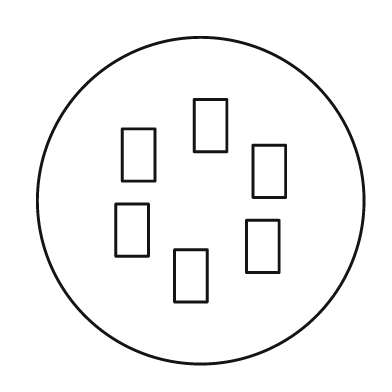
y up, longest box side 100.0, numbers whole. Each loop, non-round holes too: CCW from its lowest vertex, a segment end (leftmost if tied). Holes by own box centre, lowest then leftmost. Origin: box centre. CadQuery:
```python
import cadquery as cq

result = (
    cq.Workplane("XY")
    .moveTo(0.0, 0.0)
    .circle(50.0)
    .moveTo(-8.0, -31.0)
    .lineTo(2.0, -31.0)
    .lineTo(2.0, -15.0)
    .lineTo(-8.0, -15.0)
    .close()
    .moveTo(14.0, -22.0)
    .lineTo(24.0, -22.0)
    .lineTo(24.0, -6.0)
    .lineTo(14.0, -6.0)
    .close()
    .moveTo(-26.0, -17.0)
    .lineTo(-16.0, -17.0)
    .lineTo(-16.0, -1.0)
    .lineTo(-26.0, -1.0)
    .close()
    .moveTo(16.0, 1.0)
    .lineTo(26.0, 1.0)
    .lineTo(26.0, 17.0)
    .lineTo(16.0, 17.0)
    .close()
    .moveTo(-24.0, 6.0)
    .lineTo(-14.0, 6.0)
    .lineTo(-14.0, 22.0)
    .lineTo(-24.0, 22.0)
    .close()
    .moveTo(-2.0, 15.0)
    .lineTo(8.0, 15.0)
    .lineTo(8.0, 31.0)
    .lineTo(-2.0, 31.0)
    .close()
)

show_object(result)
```